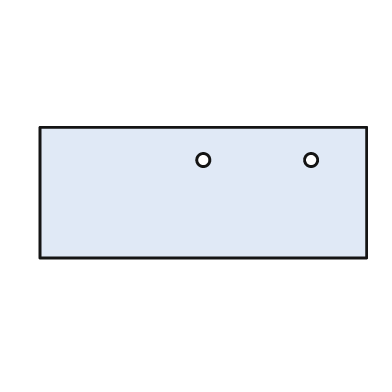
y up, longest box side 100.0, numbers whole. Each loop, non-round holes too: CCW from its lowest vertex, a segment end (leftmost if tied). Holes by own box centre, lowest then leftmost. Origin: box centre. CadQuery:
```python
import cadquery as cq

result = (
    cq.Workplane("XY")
    .moveTo(-50.0, -20.0)
    .lineTo(50.0, -20.0)
    .lineTo(50.0, 20.0)
    .lineTo(-50.0, 20.0)
    .close()
    .moveTo(0.0, 10.0)
    .circle(2.0)
    .moveTo(33.0, 10.0)
    .circle(2.0)
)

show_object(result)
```